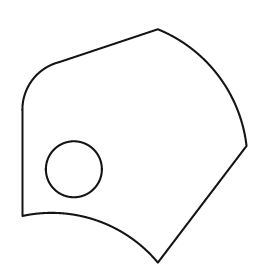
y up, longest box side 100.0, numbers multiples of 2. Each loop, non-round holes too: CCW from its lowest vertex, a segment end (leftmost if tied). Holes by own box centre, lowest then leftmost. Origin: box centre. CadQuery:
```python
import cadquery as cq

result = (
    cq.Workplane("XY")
    .moveTo(10.0, -50.0)
    .lineTo(48.0, 0.0)
    .threePointArc((36.0, 30.0), (10.0, 50.0))
    .lineTo(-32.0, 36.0)
    .threePointArc((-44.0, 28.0), (-48.0, 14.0))
    .lineTo(-48.0, -30.0)
    .threePointArc((-16.0, -32.0), (10.0, -50.0))
    .close()
    .moveTo(-26.0, -10.0)
    .circle(12.0)
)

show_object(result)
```